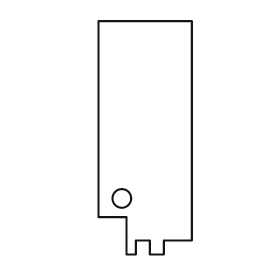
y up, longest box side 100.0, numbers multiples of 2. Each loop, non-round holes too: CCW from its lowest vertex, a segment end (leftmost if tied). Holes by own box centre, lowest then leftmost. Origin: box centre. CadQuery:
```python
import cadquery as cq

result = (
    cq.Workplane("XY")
    .moveTo(-8.0, -50.0)
    .lineTo(-4.0, -50.0)
    .lineTo(-4.0, -44.0)
    .lineTo(2.0, -44.0)
    .lineTo(2.0, -50.0)
    .lineTo(8.0, -50.0)
    .lineTo(8.0, -44.0)
    .lineTo(20.0, -44.0)
    .lineTo(20.0, 50.0)
    .lineTo(-20.0, 50.0)
    .lineTo(-20.0, -34.0)
    .lineTo(-8.0, -34.0)
    .close()
    .moveTo(-10.0, -26.0)
    .circle(4.0)
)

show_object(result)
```